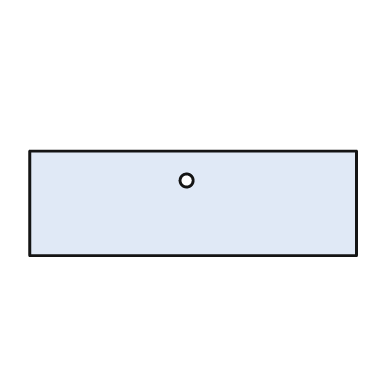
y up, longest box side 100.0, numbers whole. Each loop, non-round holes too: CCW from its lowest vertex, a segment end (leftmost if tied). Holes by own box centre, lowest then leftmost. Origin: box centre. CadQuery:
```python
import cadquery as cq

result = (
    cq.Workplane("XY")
    .moveTo(-50.0, -16.0)
    .lineTo(50.0, -16.0)
    .lineTo(50.0, 16.0)
    .lineTo(-50.0, 16.0)
    .close()
    .moveTo(-2.0, 7.0)
    .circle(2.0)
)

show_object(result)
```